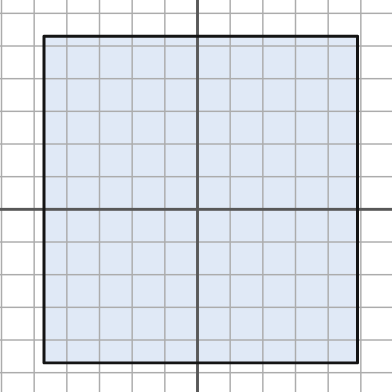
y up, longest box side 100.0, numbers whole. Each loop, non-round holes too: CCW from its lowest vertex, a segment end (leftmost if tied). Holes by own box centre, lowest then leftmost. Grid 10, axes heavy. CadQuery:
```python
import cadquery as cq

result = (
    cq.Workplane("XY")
    .moveTo(-47.0, -47.0)
    .lineTo(49.0, -47.0)
    .lineTo(49.0, 53.0)
    .lineTo(-47.0, 53.0)
    .close()
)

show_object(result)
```